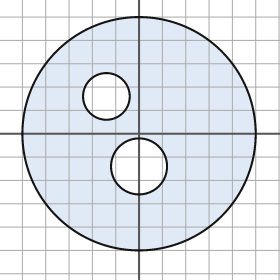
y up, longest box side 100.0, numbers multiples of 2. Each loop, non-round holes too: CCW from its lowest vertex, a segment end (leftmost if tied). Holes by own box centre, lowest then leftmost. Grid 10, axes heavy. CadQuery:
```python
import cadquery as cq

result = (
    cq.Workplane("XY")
    .moveTo(0.0, 0.0)
    .circle(50.0)
    .moveTo(0.0, -14.0)
    .circle(12.0)
    .moveTo(-14.0, 16.0)
    .circle(10.0)
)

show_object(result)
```